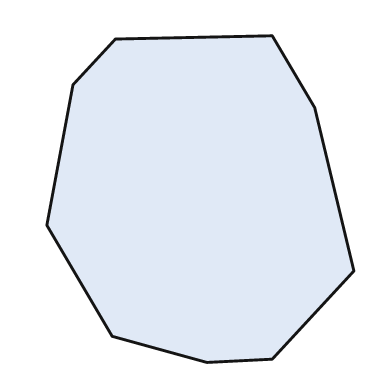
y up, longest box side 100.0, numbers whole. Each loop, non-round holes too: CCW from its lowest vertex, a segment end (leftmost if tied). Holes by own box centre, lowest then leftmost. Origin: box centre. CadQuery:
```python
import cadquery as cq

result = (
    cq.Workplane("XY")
    .moveTo(2.0, -50.0)
    .lineTo(22.0, -49.0)
    .lineTo(47.0, -22.0)
    .lineTo(35.0, 28.0)
    .lineTo(22.0, 50.0)
    .lineTo(-26.0, 49.0)
    .lineTo(-39.0, 35.0)
    .lineTo(-47.0, -8.0)
    .lineTo(-27.0, -42.0)
    .close()
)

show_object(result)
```